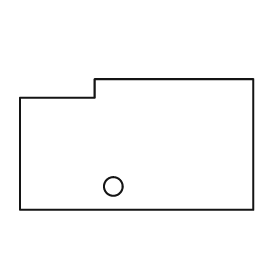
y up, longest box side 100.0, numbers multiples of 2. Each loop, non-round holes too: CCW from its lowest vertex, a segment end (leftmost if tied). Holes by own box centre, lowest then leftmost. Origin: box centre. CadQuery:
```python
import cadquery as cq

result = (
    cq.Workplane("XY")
    .moveTo(-50.0, -28.0)
    .lineTo(50.0, -28.0)
    .lineTo(50.0, 28.0)
    .lineTo(-18.0, 28.0)
    .lineTo(-18.0, 20.0)
    .lineTo(-50.0, 20.0)
    .close()
    .moveTo(-10.0, -18.0)
    .circle(4.0)
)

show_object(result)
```